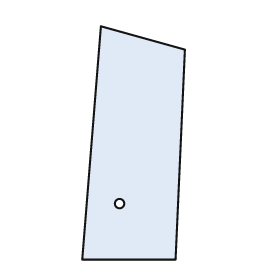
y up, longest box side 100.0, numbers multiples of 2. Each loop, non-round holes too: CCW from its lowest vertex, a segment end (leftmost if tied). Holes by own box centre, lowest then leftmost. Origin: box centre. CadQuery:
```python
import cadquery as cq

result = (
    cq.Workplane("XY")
    .moveTo(-22.0, -50.0)
    .lineTo(18.0, -50.0)
    .lineTo(22.0, 40.0)
    .lineTo(-14.0, 50.0)
    .close()
    .moveTo(-6.0, -26.0)
    .circle(2.0)
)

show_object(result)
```